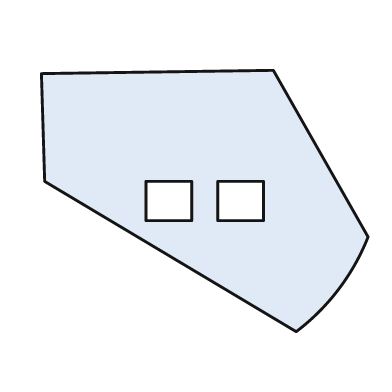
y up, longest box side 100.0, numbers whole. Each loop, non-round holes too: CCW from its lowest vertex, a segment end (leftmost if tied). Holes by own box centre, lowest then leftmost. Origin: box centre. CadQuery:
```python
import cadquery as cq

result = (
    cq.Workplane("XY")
    .moveTo(28.0, -40.0)
    .threePointArc((41.0, -27.0), (50.0, -11.0))
    .lineTo(21.0, 40.0)
    .lineTo(-50.0, 39.0)
    .lineTo(-49.0, 6.0)
    .close()
    .moveTo(-18.0, -6.0)
    .lineTo(-4.0, -6.0)
    .lineTo(-4.0, 6.0)
    .lineTo(-18.0, 6.0)
    .close()
    .moveTo(4.0, -6.0)
    .lineTo(18.0, -6.0)
    .lineTo(18.0, 6.0)
    .lineTo(4.0, 6.0)
    .close()
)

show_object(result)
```